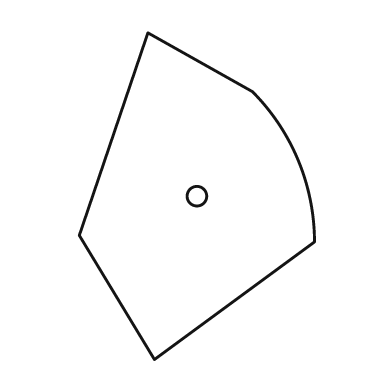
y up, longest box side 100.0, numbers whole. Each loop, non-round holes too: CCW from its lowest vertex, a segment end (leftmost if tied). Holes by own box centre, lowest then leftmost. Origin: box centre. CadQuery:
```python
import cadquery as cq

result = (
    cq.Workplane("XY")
    .moveTo(-13.0, -50.0)
    .lineTo(36.0, -14.0)
    .threePointArc((31.0, 11.0), (17.0, 32.0))
    .lineTo(-15.0, 50.0)
    .lineTo(-36.0, -12.0)
    .close()
    .moveTo(0.0, 0.0)
    .circle(3.0)
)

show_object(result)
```